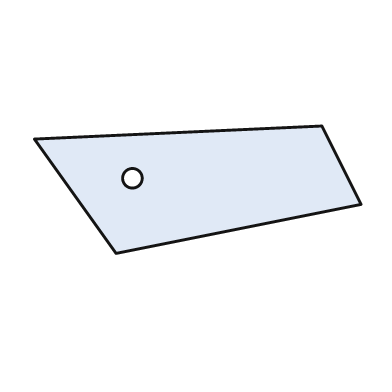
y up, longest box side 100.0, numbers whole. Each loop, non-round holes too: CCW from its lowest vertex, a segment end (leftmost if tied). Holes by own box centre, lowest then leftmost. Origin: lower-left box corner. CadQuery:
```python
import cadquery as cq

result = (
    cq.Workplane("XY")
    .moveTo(25.0, 0.0)
    .lineTo(100.0, 15.0)
    .lineTo(88.0, 39.0)
    .lineTo(0.0, 35.0)
    .close()
    .moveTo(30.0, 23.0)
    .circle(3.0)
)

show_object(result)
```